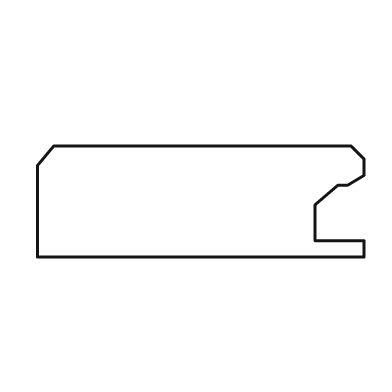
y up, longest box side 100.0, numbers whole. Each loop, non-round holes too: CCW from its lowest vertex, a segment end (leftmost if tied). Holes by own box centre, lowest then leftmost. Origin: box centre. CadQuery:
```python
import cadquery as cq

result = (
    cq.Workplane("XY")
    .moveTo(-50.0, -17.0)
    .lineTo(50.0, -17.0)
    .lineTo(50.0, -12.0)
    .lineTo(35.0, -12.0)
    .lineTo(35.0, -1.0)
    .lineTo(42.0, 5.0)
    .lineTo(45.0, 5.0)
    .lineTo(50.0, 8.0)
    .lineTo(50.0, 13.0)
    .lineTo(46.0, 17.0)
    .lineTo(-45.0, 17.0)
    .lineTo(-50.0, 11.0)
    .close()
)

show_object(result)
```